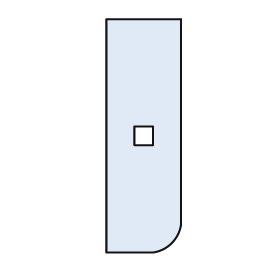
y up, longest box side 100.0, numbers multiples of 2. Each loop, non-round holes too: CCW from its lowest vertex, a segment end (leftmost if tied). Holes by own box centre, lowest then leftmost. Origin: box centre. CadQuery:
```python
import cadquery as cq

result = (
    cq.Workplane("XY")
    .moveTo(-16.0, -50.0)
    .lineTo(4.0, -50.0)
    .threePointArc((12.0, -46.0), (16.0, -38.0))
    .lineTo(16.0, 50.0)
    .lineTo(-16.0, 50.0)
    .close()
    .moveTo(-4.0, -4.0)
    .lineTo(4.0, -4.0)
    .lineTo(4.0, 4.0)
    .lineTo(-4.0, 4.0)
    .close()
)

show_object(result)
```